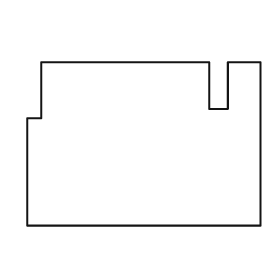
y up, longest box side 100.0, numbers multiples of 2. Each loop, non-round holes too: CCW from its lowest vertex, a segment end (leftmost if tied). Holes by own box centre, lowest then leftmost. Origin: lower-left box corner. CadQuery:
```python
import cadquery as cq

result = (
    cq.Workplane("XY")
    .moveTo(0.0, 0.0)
    .lineTo(100.0, 0.0)
    .lineTo(100.0, 70.0)
    .lineTo(86.0, 70.0)
    .lineTo(86.0, 50.0)
    .lineTo(78.0, 50.0)
    .lineTo(78.0, 70.0)
    .lineTo(6.0, 70.0)
    .lineTo(6.0, 46.0)
    .lineTo(0.0, 46.0)
    .close()
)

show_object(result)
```